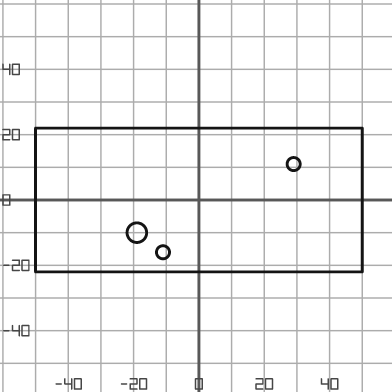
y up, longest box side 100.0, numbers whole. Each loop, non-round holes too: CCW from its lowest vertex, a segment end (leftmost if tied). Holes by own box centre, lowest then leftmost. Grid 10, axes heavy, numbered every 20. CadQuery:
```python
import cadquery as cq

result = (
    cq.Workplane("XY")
    .moveTo(-50.0, -22.0)
    .lineTo(50.0, -22.0)
    .lineTo(50.0, 22.0)
    .lineTo(-50.0, 22.0)
    .close()
    .moveTo(-11.0, -16.0)
    .circle(2.0)
    .moveTo(-19.0, -10.0)
    .circle(3.0)
    .moveTo(29.0, 11.0)
    .circle(2.0)
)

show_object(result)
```